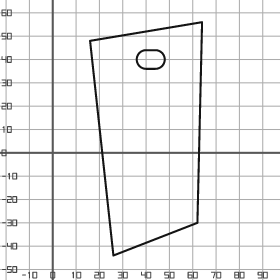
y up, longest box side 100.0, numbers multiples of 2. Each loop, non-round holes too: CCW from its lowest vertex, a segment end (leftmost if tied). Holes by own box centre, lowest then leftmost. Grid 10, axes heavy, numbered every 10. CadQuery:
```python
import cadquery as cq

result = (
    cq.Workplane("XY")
    .moveTo(26.0, -44.0)
    .lineTo(62.0, -30.0)
    .lineTo(64.0, 56.0)
    .lineTo(16.0, 48.0)
    .close()
    .moveTo(40.0, 36.0)
    .lineTo(44.0, 36.0)
    .threePointArc((48.0, 40.0), (44.0, 44.0))
    .lineTo(40.0, 44.0)
    .threePointArc((36.0, 40.0), (40.0, 36.0))
    .close()
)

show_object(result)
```